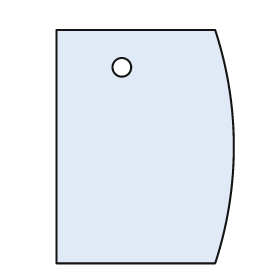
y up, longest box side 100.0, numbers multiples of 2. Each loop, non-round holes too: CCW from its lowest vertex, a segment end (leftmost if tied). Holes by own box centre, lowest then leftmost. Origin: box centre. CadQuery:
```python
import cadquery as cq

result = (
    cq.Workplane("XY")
    .moveTo(-38.0, -50.0)
    .lineTo(30.0, -50.0)
    .threePointArc((38.0, 0.0), (30.0, 50.0))
    .lineTo(-38.0, 50.0)
    .close()
    .moveTo(-10.0, 34.0)
    .circle(4.0)
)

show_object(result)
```